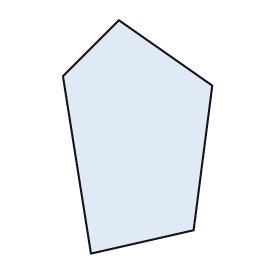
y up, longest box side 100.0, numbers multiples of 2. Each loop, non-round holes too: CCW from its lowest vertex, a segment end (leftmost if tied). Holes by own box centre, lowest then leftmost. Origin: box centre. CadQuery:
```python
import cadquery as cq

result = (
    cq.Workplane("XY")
    .moveTo(-20.0, -50.0)
    .lineTo(24.0, -40.0)
    .lineTo(32.0, 22.0)
    .lineTo(-8.0, 50.0)
    .lineTo(-32.0, 26.0)
    .close()
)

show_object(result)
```